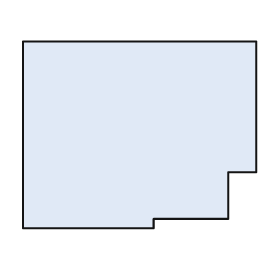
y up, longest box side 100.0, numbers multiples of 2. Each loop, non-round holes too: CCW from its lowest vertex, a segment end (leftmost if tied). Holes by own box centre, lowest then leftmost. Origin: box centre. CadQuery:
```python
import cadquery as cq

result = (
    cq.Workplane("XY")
    .moveTo(-50.0, -40.0)
    .lineTo(6.0, -40.0)
    .lineTo(6.0, -36.0)
    .lineTo(38.0, -36.0)
    .lineTo(38.0, -16.0)
    .lineTo(50.0, -16.0)
    .lineTo(50.0, 40.0)
    .lineTo(-50.0, 40.0)
    .close()
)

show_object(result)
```